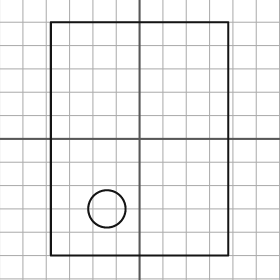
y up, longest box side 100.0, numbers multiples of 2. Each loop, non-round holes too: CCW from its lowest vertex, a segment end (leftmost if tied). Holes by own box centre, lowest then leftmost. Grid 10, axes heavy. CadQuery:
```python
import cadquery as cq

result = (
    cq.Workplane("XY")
    .moveTo(-38.0, -50.0)
    .lineTo(38.0, -50.0)
    .lineTo(38.0, 50.0)
    .lineTo(-38.0, 50.0)
    .close()
    .moveTo(-14.0, -30.0)
    .circle(8.0)
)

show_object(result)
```